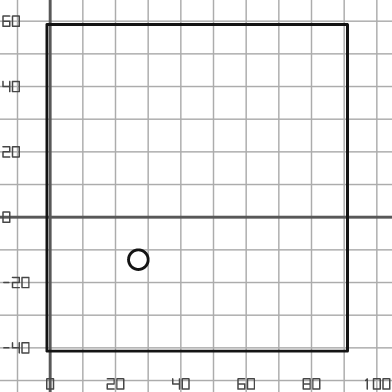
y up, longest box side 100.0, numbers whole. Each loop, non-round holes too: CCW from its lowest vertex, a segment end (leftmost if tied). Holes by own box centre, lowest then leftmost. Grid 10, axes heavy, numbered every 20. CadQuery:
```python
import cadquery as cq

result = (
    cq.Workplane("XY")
    .moveTo(-1.0, -41.0)
    .lineTo(91.0, -41.0)
    .lineTo(91.0, 59.0)
    .lineTo(-1.0, 59.0)
    .close()
    .moveTo(27.0, -13.0)
    .circle(3.0)
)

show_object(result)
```